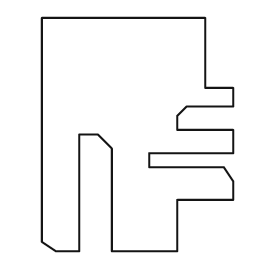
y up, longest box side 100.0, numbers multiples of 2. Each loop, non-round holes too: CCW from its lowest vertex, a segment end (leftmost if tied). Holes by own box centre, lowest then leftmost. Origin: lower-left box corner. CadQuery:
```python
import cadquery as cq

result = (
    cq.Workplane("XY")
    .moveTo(6.0, 0.0)
    .lineTo(16.0, 0.0)
    .lineTo(16.0, 50.0)
    .lineTo(24.0, 50.0)
    .lineTo(30.0, 44.0)
    .lineTo(30.0, 0.0)
    .lineTo(58.0, 0.0)
    .lineTo(58.0, 22.0)
    .lineTo(82.0, 22.0)
    .lineTo(82.0, 30.0)
    .lineTo(78.0, 36.0)
    .lineTo(46.0, 36.0)
    .lineTo(46.0, 42.0)
    .lineTo(82.0, 42.0)
    .lineTo(82.0, 52.0)
    .lineTo(58.0, 52.0)
    .lineTo(58.0, 58.0)
    .lineTo(62.0, 62.0)
    .lineTo(82.0, 62.0)
    .lineTo(82.0, 70.0)
    .lineTo(70.0, 70.0)
    .lineTo(70.0, 100.0)
    .lineTo(0.0, 100.0)
    .lineTo(0.0, 4.0)
    .close()
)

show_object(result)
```